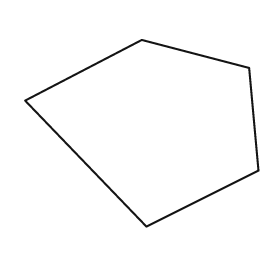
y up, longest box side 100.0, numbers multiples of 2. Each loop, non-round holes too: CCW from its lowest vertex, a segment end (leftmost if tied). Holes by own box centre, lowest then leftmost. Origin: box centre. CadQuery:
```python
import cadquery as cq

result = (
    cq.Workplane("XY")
    .moveTo(2.0, -40.0)
    .lineTo(50.0, -16.0)
    .lineTo(46.0, 28.0)
    .lineTo(0.0, 40.0)
    .lineTo(-50.0, 14.0)
    .close()
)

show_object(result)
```